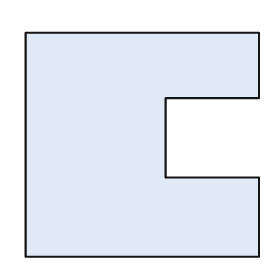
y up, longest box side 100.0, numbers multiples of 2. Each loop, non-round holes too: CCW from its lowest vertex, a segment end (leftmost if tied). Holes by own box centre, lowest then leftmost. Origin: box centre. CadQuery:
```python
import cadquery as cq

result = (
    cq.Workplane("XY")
    .moveTo(-50.0, -48.0)
    .lineTo(50.0, -48.0)
    .lineTo(50.0, -14.0)
    .lineTo(10.0, -14.0)
    .lineTo(10.0, 20.0)
    .lineTo(50.0, 20.0)
    .lineTo(50.0, 48.0)
    .lineTo(-50.0, 48.0)
    .close()
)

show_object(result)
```